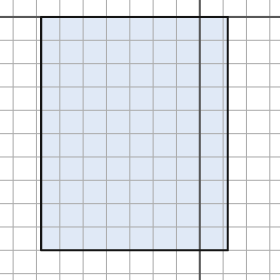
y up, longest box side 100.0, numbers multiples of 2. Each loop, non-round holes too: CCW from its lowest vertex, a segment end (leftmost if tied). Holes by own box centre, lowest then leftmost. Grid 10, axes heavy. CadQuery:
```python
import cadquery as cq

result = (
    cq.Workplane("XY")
    .moveTo(-68.0, -100.0)
    .lineTo(12.0, -100.0)
    .lineTo(12.0, 0.0)
    .lineTo(-68.0, 0.0)
    .close()
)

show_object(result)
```